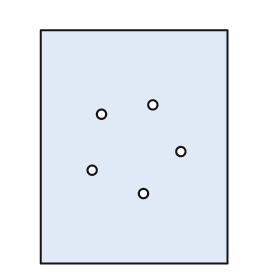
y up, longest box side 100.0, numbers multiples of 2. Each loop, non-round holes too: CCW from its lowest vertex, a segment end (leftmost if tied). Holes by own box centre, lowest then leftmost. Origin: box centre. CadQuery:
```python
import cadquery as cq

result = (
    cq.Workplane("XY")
    .moveTo(-40.0, -50.0)
    .lineTo(40.0, -50.0)
    .lineTo(40.0, 50.0)
    .lineTo(-40.0, 50.0)
    .close()
    .moveTo(4.0, -20.0)
    .circle(2.0)
    .moveTo(-18.0, -10.0)
    .circle(2.0)
    .moveTo(20.0, -2.0)
    .circle(2.0)
    .moveTo(-14.0, 14.0)
    .circle(2.0)
    .moveTo(8.0, 18.0)
    .circle(2.0)
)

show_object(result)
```